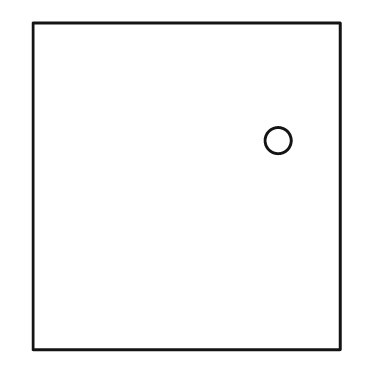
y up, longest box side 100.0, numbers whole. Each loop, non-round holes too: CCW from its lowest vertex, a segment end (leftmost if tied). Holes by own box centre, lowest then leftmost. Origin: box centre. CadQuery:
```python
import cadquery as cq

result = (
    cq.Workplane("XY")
    .moveTo(-47.0, -50.0)
    .lineTo(47.0, -50.0)
    .lineTo(47.0, 50.0)
    .lineTo(-47.0, 50.0)
    .close()
    .moveTo(28.0, 14.0)
    .circle(4.0)
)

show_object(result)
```